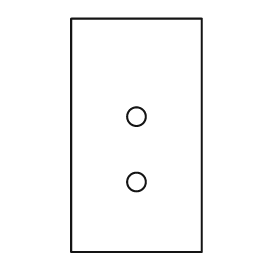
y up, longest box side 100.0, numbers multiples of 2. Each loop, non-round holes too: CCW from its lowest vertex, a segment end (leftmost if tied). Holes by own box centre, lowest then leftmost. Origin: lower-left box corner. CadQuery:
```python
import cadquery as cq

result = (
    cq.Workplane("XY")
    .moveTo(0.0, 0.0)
    .lineTo(56.0, 0.0)
    .lineTo(56.0, 100.0)
    .lineTo(0.0, 100.0)
    .close()
    .moveTo(28.0, 30.0)
    .circle(4.0)
    .moveTo(28.0, 58.0)
    .circle(4.0)
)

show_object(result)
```